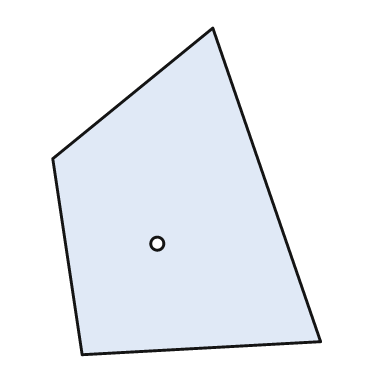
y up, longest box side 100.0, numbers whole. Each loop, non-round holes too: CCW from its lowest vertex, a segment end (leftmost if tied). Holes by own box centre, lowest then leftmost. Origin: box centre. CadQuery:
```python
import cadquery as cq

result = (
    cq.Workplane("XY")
    .moveTo(-32.0, -50.0)
    .lineTo(41.0, -46.0)
    .lineTo(8.0, 50.0)
    .lineTo(-41.0, 10.0)
    .close()
    .moveTo(-9.0, -16.0)
    .circle(2.0)
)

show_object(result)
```